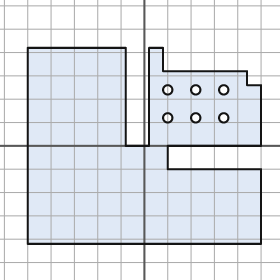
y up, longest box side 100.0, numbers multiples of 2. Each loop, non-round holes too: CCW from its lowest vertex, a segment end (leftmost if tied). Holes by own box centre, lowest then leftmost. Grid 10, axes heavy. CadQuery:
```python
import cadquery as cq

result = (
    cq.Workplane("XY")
    .moveTo(-50.0, -42.0)
    .lineTo(50.0, -42.0)
    .lineTo(50.0, -10.0)
    .lineTo(10.0, -10.0)
    .lineTo(10.0, 0.0)
    .lineTo(50.0, 0.0)
    .lineTo(50.0, 26.0)
    .lineTo(44.0, 26.0)
    .lineTo(44.0, 32.0)
    .lineTo(8.0, 32.0)
    .lineTo(8.0, 42.0)
    .lineTo(2.0, 42.0)
    .lineTo(2.0, 0.0)
    .lineTo(-8.0, 0.0)
    .lineTo(-8.0, 42.0)
    .lineTo(-50.0, 42.0)
    .close()
    .moveTo(10.0, 12.0)
    .circle(2.0)
    .moveTo(22.0, 12.0)
    .circle(2.0)
    .moveTo(34.0, 12.0)
    .circle(2.0)
    .moveTo(10.0, 24.0)
    .circle(2.0)
    .moveTo(22.0, 24.0)
    .circle(2.0)
    .moveTo(34.0, 24.0)
    .circle(2.0)
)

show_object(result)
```